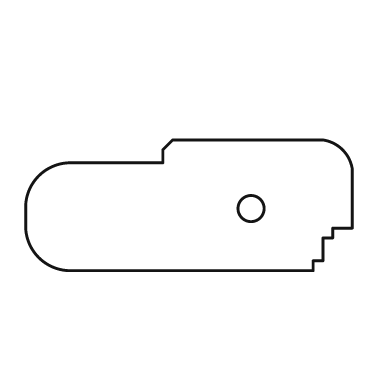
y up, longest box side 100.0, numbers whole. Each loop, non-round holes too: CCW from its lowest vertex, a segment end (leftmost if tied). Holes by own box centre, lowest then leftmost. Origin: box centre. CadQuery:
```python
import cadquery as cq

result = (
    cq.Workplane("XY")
    .moveTo(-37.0, -20.0)
    .lineTo(38.0, -20.0)
    .lineTo(38.0, -17.0)
    .lineTo(41.0, -17.0)
    .lineTo(41.0, -10.0)
    .lineTo(44.0, -10.0)
    .lineTo(44.0, -7.0)
    .lineTo(50.0, -7.0)
    .lineTo(50.0, 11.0)
    .threePointArc((47.0, 17.0), (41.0, 20.0))
    .lineTo(-5.0, 20.0)
    .lineTo(-8.0, 17.0)
    .lineTo(-8.0, 13.0)
    .lineTo(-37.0, 13.0)
    .threePointArc((-46.0, 9.0), (-50.0, 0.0))
    .lineTo(-50.0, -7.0)
    .threePointArc((-46.0, -16.0), (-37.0, -20.0))
    .close()
    .moveTo(19.0, -1.0)
    .circle(4.0)
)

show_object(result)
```